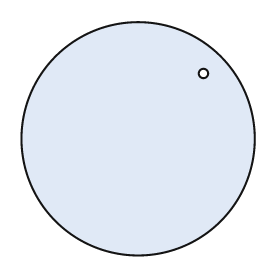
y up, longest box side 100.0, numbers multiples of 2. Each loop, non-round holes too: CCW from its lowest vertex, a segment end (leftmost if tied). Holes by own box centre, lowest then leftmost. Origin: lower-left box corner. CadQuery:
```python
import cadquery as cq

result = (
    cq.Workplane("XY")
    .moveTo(50.0, 50.0)
    .circle(50.0)
    .moveTo(78.0, 78.0)
    .circle(2.0)
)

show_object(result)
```